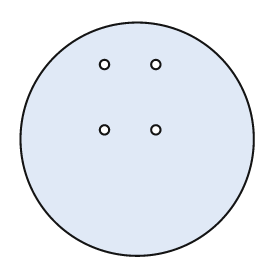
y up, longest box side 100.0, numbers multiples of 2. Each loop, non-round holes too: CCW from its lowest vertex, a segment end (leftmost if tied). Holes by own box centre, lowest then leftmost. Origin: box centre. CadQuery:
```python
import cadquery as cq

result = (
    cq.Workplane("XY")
    .moveTo(0.0, 0.0)
    .circle(50.0)
    .moveTo(-14.0, 4.0)
    .circle(2.0)
    .moveTo(8.0, 4.0)
    .circle(2.0)
    .moveTo(-14.0, 32.0)
    .circle(2.0)
    .moveTo(8.0, 32.0)
    .circle(2.0)
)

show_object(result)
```